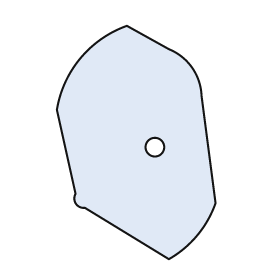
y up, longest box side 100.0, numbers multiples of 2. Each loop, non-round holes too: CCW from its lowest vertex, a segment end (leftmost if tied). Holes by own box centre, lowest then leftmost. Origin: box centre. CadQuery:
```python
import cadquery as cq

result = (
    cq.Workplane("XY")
    .moveTo(14.0, -50.0)
    .threePointArc((26.0, -40.0), (34.0, -26.0))
    .lineTo(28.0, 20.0)
    .threePointArc((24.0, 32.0), (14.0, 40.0))
    .lineTo(-4.0, 50.0)
    .threePointArc((-24.0, 36.0), (-34.0, 14.0))
    .lineTo(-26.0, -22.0)
    .threePointArc((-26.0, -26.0), (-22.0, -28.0))
    .close()
    .moveTo(8.0, -2.0)
    .circle(4.0)
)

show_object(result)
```